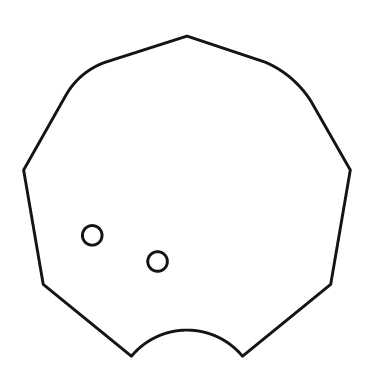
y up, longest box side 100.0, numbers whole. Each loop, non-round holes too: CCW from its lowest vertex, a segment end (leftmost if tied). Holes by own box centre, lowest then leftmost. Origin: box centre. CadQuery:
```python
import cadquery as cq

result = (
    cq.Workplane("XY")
    .moveTo(-17.0, -49.0)
    .threePointArc((0.0, -41.0), (17.0, -49.0))
    .lineTo(44.0, -27.0)
    .lineTo(50.0, 8.0)
    .lineTo(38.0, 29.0)
    .threePointArc((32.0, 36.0), (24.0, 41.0))
    .lineTo(0.0, 49.0)
    .lineTo(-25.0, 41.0)
    .threePointArc((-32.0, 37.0), (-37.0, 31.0))
    .lineTo(-50.0, 8.0)
    .lineTo(-44.0, -27.0)
    .close()
    .moveTo(-9.0, -20.0)
    .circle(3.0)
    .moveTo(-29.0, -12.0)
    .circle(3.0)
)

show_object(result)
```